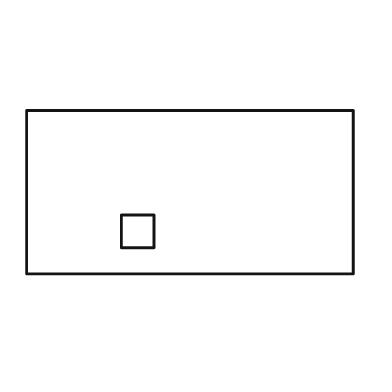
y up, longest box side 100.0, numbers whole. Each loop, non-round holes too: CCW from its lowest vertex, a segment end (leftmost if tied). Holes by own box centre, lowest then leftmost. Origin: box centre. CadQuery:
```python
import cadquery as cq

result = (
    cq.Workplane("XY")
    .moveTo(-50.0, -25.0)
    .lineTo(50.0, -25.0)
    .lineTo(50.0, 25.0)
    .lineTo(-50.0, 25.0)
    .close()
    .moveTo(-21.0, -17.0)
    .lineTo(-11.0, -17.0)
    .lineTo(-11.0, -7.0)
    .lineTo(-21.0, -7.0)
    .close()
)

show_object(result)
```